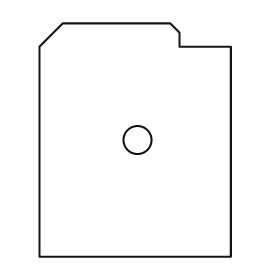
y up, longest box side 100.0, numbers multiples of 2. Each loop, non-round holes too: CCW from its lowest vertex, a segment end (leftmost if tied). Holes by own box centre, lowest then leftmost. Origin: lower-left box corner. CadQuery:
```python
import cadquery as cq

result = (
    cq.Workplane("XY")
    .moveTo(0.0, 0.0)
    .lineTo(82.0, 0.0)
    .lineTo(82.0, 90.0)
    .lineTo(60.0, 90.0)
    .lineTo(60.0, 96.0)
    .lineTo(56.0, 100.0)
    .lineTo(10.0, 100.0)
    .lineTo(0.0, 90.0)
    .close()
    .moveTo(42.0, 50.0)
    .circle(6.0)
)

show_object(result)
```